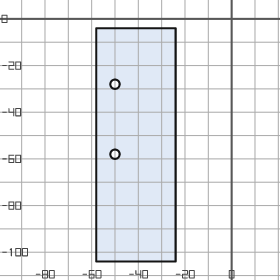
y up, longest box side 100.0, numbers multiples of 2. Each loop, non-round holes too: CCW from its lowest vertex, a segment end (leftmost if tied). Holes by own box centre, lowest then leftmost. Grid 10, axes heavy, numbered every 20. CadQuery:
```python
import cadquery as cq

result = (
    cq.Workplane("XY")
    .moveTo(-58.0, -104.0)
    .lineTo(-24.0, -104.0)
    .lineTo(-24.0, -4.0)
    .lineTo(-58.0, -4.0)
    .close()
    .moveTo(-50.0, -58.0)
    .circle(2.0)
    .moveTo(-50.0, -28.0)
    .circle(2.0)
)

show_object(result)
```